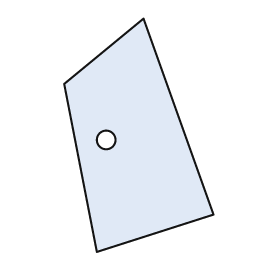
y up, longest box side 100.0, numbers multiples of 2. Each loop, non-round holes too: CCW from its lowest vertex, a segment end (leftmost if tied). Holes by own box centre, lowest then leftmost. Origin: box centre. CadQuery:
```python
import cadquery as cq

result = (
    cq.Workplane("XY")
    .moveTo(-18.0, -50.0)
    .lineTo(32.0, -34.0)
    .lineTo(2.0, 50.0)
    .lineTo(-32.0, 22.0)
    .close()
    .moveTo(-14.0, -2.0)
    .circle(4.0)
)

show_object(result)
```